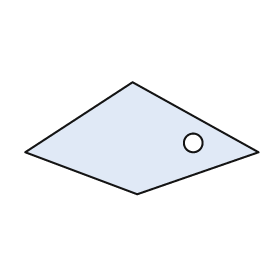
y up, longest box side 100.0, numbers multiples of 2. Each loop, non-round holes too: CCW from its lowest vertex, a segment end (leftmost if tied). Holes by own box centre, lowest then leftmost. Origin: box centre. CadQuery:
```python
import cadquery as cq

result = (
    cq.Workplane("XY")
    .moveTo(-2.0, -24.0)
    .lineTo(50.0, -6.0)
    .lineTo(-4.0, 24.0)
    .lineTo(-50.0, -6.0)
    .close()
    .moveTo(22.0, -2.0)
    .circle(4.0)
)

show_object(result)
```